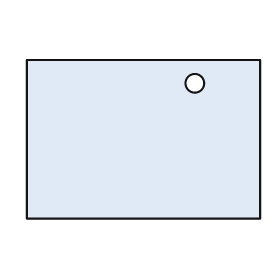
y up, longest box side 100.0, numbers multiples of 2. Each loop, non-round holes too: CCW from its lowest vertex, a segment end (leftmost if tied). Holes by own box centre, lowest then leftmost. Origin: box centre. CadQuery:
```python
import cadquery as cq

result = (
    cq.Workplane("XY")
    .moveTo(-50.0, -34.0)
    .lineTo(50.0, -34.0)
    .lineTo(50.0, 34.0)
    .lineTo(-50.0, 34.0)
    .close()
    .moveTo(22.0, 24.0)
    .circle(4.0)
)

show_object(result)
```